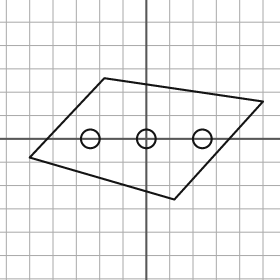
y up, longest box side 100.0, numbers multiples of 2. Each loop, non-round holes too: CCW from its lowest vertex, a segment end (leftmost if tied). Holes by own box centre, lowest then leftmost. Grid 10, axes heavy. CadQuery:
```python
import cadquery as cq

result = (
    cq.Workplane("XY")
    .moveTo(12.0, -26.0)
    .lineTo(50.0, 16.0)
    .lineTo(-18.0, 26.0)
    .lineTo(-50.0, -8.0)
    .close()
    .moveTo(-24.0, 0.0)
    .circle(4.0)
    .moveTo(0.0, 0.0)
    .circle(4.0)
    .moveTo(24.0, 0.0)
    .circle(4.0)
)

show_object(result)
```